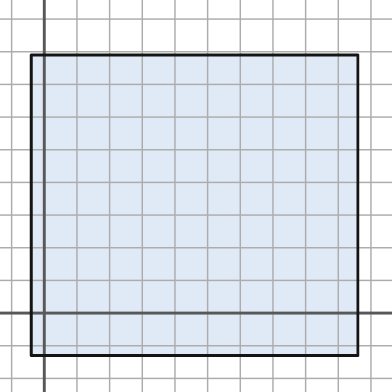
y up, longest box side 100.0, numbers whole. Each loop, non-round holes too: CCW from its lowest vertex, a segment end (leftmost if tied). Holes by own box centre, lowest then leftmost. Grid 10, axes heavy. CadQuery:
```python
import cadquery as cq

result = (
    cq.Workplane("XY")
    .moveTo(-4.0, -13.0)
    .lineTo(96.0, -13.0)
    .lineTo(96.0, 79.0)
    .lineTo(-4.0, 79.0)
    .close()
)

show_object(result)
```